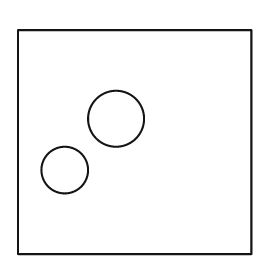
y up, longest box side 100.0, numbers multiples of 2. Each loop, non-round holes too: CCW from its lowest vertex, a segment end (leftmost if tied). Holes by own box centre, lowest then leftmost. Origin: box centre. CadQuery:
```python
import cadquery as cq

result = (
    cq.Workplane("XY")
    .moveTo(-50.0, -48.0)
    .lineTo(50.0, -48.0)
    .lineTo(50.0, 48.0)
    .lineTo(-50.0, 48.0)
    .close()
    .moveTo(-30.0, -12.0)
    .circle(10.0)
    .moveTo(-8.0, 10.0)
    .circle(12.0)
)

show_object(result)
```